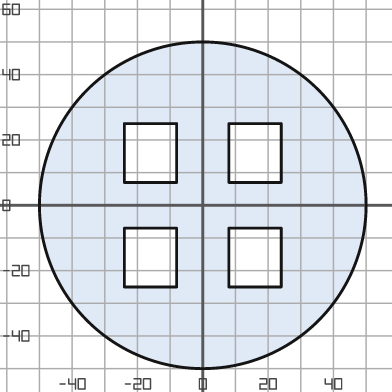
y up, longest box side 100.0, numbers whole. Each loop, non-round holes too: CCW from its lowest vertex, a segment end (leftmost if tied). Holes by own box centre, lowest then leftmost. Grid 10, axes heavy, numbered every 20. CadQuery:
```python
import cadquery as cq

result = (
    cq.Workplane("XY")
    .moveTo(0.0, 0.0)
    .circle(50.0)
    .moveTo(-24.0, -25.0)
    .lineTo(-8.0, -25.0)
    .lineTo(-8.0, -7.0)
    .lineTo(-24.0, -7.0)
    .close()
    .moveTo(8.0, -25.0)
    .lineTo(24.0, -25.0)
    .lineTo(24.0, -7.0)
    .lineTo(8.0, -7.0)
    .close()
    .moveTo(-24.0, 7.0)
    .lineTo(-8.0, 7.0)
    .lineTo(-8.0, 25.0)
    .lineTo(-24.0, 25.0)
    .close()
    .moveTo(8.0, 7.0)
    .lineTo(24.0, 7.0)
    .lineTo(24.0, 25.0)
    .lineTo(8.0, 25.0)
    .close()
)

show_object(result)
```